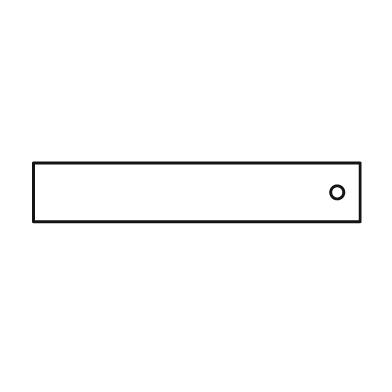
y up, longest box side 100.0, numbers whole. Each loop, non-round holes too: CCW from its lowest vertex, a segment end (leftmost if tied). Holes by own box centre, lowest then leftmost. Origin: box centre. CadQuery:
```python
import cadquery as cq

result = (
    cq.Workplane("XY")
    .moveTo(-50.0, -9.0)
    .lineTo(50.0, -9.0)
    .lineTo(50.0, 9.0)
    .lineTo(-50.0, 9.0)
    .close()
    .moveTo(43.0, 0.0)
    .circle(2.0)
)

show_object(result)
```